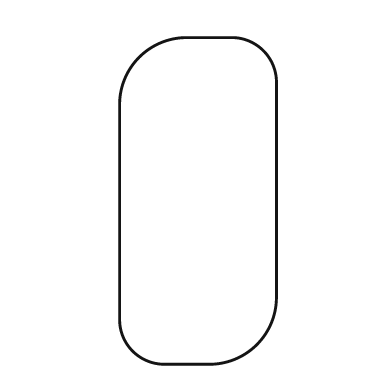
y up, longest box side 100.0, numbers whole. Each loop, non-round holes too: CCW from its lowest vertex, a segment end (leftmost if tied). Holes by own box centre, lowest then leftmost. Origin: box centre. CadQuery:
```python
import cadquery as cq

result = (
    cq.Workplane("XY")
    .moveTo(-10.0, -50.0)
    .lineTo(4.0, -50.0)
    .threePointArc((18.0, -44.0), (24.0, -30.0))
    .lineTo(24.0, 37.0)
    .threePointArc((20.0, 46.0), (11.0, 50.0))
    .lineTo(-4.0, 50.0)
    .threePointArc((-18.0, 44.0), (-24.0, 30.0))
    .lineTo(-24.0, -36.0)
    .threePointArc((-20.0, -46.0), (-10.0, -50.0))
    .close()
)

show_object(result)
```